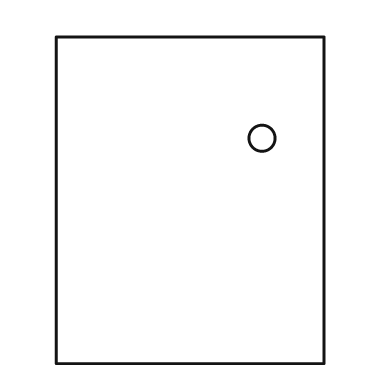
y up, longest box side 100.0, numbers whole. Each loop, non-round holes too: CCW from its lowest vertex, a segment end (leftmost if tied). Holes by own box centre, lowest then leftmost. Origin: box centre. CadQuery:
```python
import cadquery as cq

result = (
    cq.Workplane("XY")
    .moveTo(-41.0, -50.0)
    .lineTo(41.0, -50.0)
    .lineTo(41.0, 50.0)
    .lineTo(-41.0, 50.0)
    .close()
    .moveTo(22.0, 19.0)
    .circle(4.0)
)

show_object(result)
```